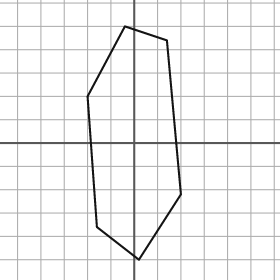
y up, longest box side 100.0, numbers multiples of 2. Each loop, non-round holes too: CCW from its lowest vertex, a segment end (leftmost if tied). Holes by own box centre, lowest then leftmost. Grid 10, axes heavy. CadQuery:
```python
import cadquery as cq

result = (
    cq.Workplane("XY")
    .moveTo(2.0, -50.0)
    .lineTo(20.0, -22.0)
    .lineTo(14.0, 44.0)
    .lineTo(-4.0, 50.0)
    .lineTo(-20.0, 20.0)
    .lineTo(-16.0, -36.0)
    .close()
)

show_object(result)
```